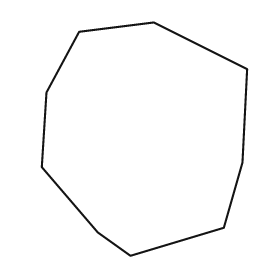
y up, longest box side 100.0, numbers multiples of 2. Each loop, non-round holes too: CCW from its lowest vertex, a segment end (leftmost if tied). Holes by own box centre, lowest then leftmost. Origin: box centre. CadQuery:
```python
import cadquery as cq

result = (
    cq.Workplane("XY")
    .moveTo(-6.0, -50.0)
    .lineTo(34.0, -38.0)
    .lineTo(42.0, -10.0)
    .lineTo(44.0, 30.0)
    .lineTo(4.0, 50.0)
    .lineTo(-28.0, 46.0)
    .lineTo(-42.0, 20.0)
    .lineTo(-44.0, -12.0)
    .lineTo(-20.0, -40.0)
    .close()
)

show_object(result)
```